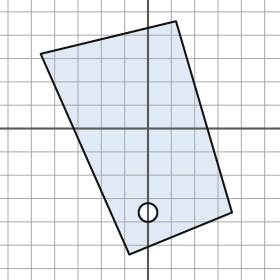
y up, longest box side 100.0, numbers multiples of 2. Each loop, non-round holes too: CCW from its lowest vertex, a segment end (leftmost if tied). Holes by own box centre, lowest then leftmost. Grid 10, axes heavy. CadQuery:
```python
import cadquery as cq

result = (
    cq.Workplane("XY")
    .moveTo(-8.0, -54.0)
    .lineTo(36.0, -36.0)
    .lineTo(12.0, 46.0)
    .lineTo(-46.0, 32.0)
    .close()
    .moveTo(0.0, -36.0)
    .circle(4.0)
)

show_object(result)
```